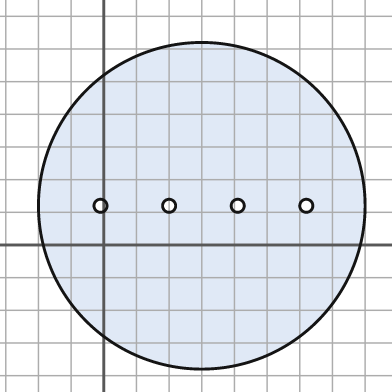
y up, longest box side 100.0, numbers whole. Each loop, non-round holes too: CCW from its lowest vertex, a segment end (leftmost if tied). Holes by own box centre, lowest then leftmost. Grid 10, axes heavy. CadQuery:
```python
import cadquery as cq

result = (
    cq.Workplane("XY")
    .moveTo(30.0, 12.0)
    .circle(50.0)
    .moveTo(-1.0, 12.0)
    .circle(2.0)
    .moveTo(20.0, 12.0)
    .circle(2.0)
    .moveTo(41.0, 12.0)
    .circle(2.0)
    .moveTo(62.0, 12.0)
    .circle(2.0)
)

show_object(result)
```